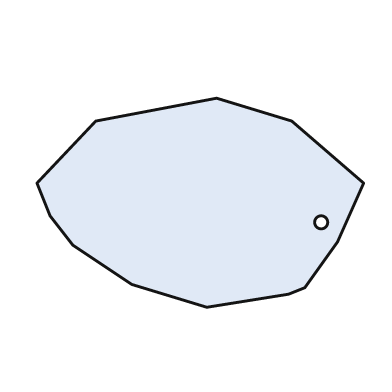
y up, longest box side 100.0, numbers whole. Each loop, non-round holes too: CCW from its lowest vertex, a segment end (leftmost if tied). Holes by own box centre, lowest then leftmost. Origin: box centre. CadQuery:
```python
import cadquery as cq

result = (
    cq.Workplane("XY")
    .moveTo(2.0, -32.0)
    .lineTo(27.0, -28.0)
    .lineTo(32.0, -26.0)
    .lineTo(42.0, -12.0)
    .lineTo(50.0, 6.0)
    .lineTo(28.0, 25.0)
    .lineTo(5.0, 32.0)
    .lineTo(-32.0, 25.0)
    .lineTo(-50.0, 6.0)
    .lineTo(-46.0, -4.0)
    .lineTo(-39.0, -13.0)
    .lineTo(-21.0, -25.0)
    .close()
    .moveTo(37.0, -6.0)
    .circle(2.0)
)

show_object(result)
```